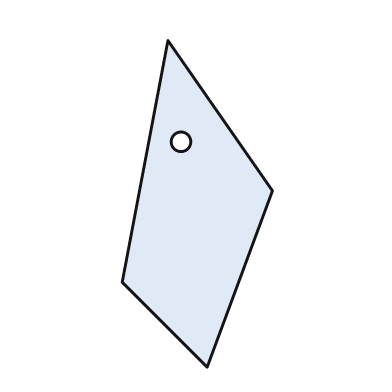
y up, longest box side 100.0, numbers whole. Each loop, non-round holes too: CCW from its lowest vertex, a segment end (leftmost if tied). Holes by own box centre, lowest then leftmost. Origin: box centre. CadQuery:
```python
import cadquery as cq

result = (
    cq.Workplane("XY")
    .moveTo(3.0, -50.0)
    .lineTo(23.0, 4.0)
    .lineTo(-9.0, 50.0)
    .lineTo(-23.0, -24.0)
    .close()
    .moveTo(-5.0, 19.0)
    .circle(3.0)
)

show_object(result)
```